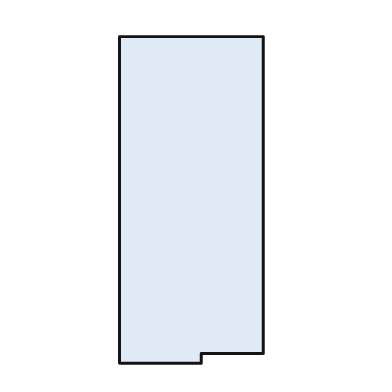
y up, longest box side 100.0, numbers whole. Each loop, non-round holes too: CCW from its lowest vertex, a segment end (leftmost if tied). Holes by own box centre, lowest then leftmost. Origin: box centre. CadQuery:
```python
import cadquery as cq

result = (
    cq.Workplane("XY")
    .moveTo(-22.0, -50.0)
    .lineTo(3.0, -50.0)
    .lineTo(3.0, -47.0)
    .lineTo(22.0, -47.0)
    .lineTo(22.0, 50.0)
    .lineTo(-22.0, 50.0)
    .close()
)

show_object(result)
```